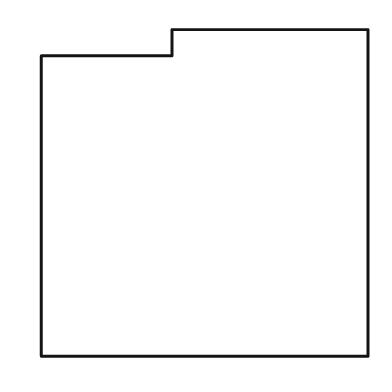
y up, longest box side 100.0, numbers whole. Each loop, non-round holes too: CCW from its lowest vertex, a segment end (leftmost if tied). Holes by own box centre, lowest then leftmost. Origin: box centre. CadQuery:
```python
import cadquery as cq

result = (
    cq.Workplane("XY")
    .moveTo(-50.0, -50.0)
    .lineTo(50.0, -50.0)
    .lineTo(50.0, 50.0)
    .lineTo(-10.0, 50.0)
    .lineTo(-10.0, 42.0)
    .lineTo(-50.0, 42.0)
    .close()
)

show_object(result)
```